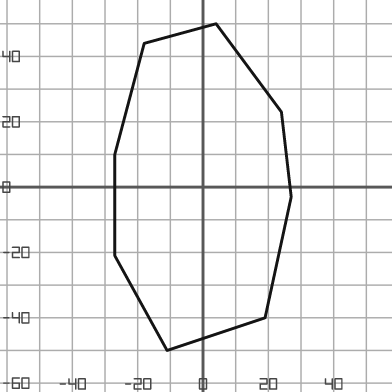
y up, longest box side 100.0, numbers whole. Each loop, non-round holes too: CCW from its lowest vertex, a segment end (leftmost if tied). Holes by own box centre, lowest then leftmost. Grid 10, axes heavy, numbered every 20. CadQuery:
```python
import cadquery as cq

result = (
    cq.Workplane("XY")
    .moveTo(-11.0, -50.0)
    .lineTo(19.0, -40.0)
    .lineTo(27.0, -3.0)
    .lineTo(24.0, 23.0)
    .lineTo(4.0, 50.0)
    .lineTo(-18.0, 44.0)
    .lineTo(-27.0, 10.0)
    .lineTo(-27.0, -21.0)
    .close()
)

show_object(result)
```